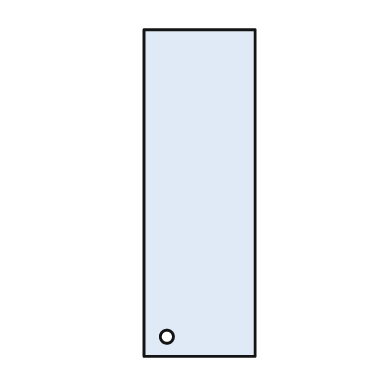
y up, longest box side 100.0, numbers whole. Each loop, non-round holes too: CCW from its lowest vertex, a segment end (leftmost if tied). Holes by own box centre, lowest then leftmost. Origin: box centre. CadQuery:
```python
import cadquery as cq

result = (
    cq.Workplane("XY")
    .moveTo(-17.0, -50.0)
    .lineTo(17.0, -50.0)
    .lineTo(17.0, 50.0)
    .lineTo(-17.0, 50.0)
    .close()
    .moveTo(-10.0, -44.0)
    .circle(2.0)
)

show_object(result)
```